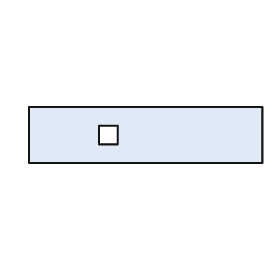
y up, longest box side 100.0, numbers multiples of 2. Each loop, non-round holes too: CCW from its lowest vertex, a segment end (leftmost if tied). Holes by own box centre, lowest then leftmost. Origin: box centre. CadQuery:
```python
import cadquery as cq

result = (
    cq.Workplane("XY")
    .moveTo(-50.0, -12.0)
    .lineTo(50.0, -12.0)
    .lineTo(50.0, 12.0)
    .lineTo(-50.0, 12.0)
    .close()
    .moveTo(-20.0, -4.0)
    .lineTo(-12.0, -4.0)
    .lineTo(-12.0, 4.0)
    .lineTo(-20.0, 4.0)
    .close()
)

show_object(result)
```